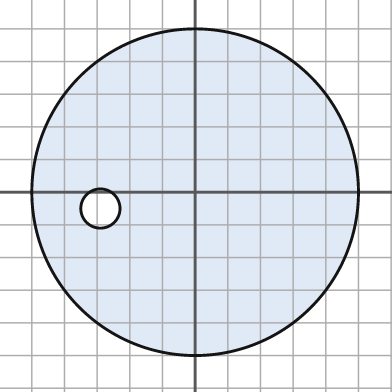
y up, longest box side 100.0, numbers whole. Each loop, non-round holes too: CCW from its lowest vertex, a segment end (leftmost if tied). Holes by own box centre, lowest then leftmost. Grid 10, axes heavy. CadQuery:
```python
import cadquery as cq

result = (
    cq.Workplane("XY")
    .moveTo(0.0, 0.0)
    .circle(50.0)
    .moveTo(-29.0, -5.0)
    .circle(6.0)
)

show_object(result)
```